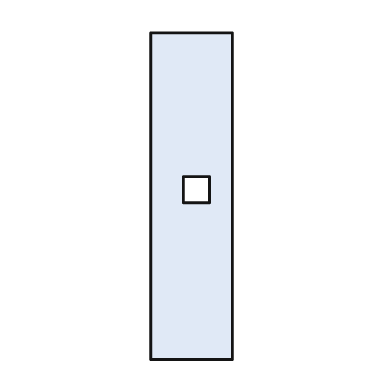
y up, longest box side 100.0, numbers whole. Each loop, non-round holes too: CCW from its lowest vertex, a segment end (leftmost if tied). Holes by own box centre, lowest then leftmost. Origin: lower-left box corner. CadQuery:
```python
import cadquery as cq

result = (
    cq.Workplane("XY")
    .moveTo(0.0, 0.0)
    .lineTo(25.0, 0.0)
    .lineTo(25.0, 100.0)
    .lineTo(0.0, 100.0)
    .close()
    .moveTo(10.0, 48.0)
    .lineTo(18.0, 48.0)
    .lineTo(18.0, 56.0)
    .lineTo(10.0, 56.0)
    .close()
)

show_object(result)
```